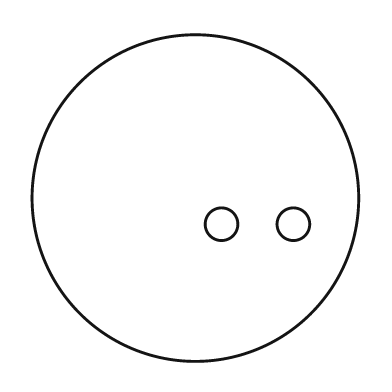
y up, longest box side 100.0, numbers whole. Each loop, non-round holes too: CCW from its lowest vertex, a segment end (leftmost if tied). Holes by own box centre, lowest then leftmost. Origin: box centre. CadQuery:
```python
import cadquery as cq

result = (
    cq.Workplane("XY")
    .moveTo(0.0, 0.0)
    .circle(50.0)
    .moveTo(8.0, -8.0)
    .circle(5.0)
    .moveTo(30.0, -8.0)
    .circle(5.0)
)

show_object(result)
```